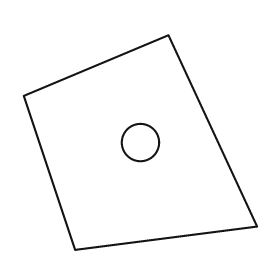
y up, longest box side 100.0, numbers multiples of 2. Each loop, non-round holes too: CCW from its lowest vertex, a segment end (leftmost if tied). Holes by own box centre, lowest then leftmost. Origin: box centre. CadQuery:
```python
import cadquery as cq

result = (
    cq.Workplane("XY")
    .moveTo(-28.0, -46.0)
    .lineTo(50.0, -36.0)
    .lineTo(12.0, 46.0)
    .lineTo(-50.0, 20.0)
    .close()
    .moveTo(0.0, 0.0)
    .circle(8.0)
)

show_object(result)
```